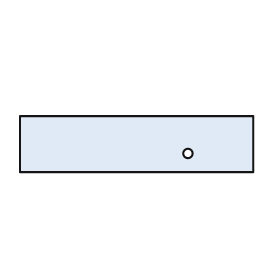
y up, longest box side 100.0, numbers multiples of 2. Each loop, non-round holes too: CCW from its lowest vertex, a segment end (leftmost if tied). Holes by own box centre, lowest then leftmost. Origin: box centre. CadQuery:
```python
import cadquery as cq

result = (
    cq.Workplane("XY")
    .moveTo(-50.0, -12.0)
    .lineTo(50.0, -12.0)
    .lineTo(50.0, 12.0)
    .lineTo(-50.0, 12.0)
    .close()
    .moveTo(22.0, -4.0)
    .circle(2.0)
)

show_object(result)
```